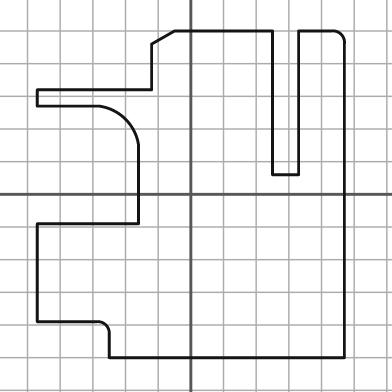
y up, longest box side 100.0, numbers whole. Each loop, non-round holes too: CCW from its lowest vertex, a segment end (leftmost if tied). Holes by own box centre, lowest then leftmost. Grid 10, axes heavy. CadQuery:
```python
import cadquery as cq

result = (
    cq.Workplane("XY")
    .moveTo(-25.0, -50.0)
    .lineTo(47.0, -50.0)
    .lineTo(47.0, 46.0)
    .threePointArc((46.0, 49.0), (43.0, 50.0))
    .lineTo(33.0, 50.0)
    .lineTo(33.0, 6.0)
    .lineTo(25.0, 6.0)
    .lineTo(25.0, 50.0)
    .lineTo(-5.0, 50.0)
    .lineTo(-12.0, 46.0)
    .lineTo(-12.0, 32.0)
    .lineTo(-47.0, 32.0)
    .lineTo(-47.0, 27.0)
    .lineTo(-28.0, 27.0)
    .threePointArc((-20.0, 23.0), (-16.0, 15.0))
    .lineTo(-16.0, -9.0)
    .lineTo(-47.0, -9.0)
    .lineTo(-47.0, -39.0)
    .lineTo(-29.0, -39.0)
    .threePointArc((-26.0, -40.0), (-25.0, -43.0))
    .close()
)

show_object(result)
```